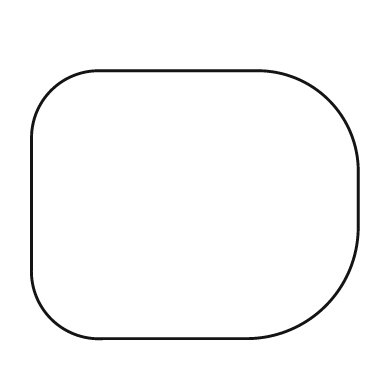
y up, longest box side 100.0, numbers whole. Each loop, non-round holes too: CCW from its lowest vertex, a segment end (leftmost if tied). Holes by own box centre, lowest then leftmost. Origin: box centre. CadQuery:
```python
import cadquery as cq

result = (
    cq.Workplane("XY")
    .moveTo(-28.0, -41.0)
    .lineTo(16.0, -41.0)
    .threePointArc((40.0, -31.0), (50.0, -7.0))
    .lineTo(50.0, 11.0)
    .threePointArc((41.0, 32.0), (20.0, 41.0))
    .lineTo(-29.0, 41.0)
    .threePointArc((-44.0, 35.0), (-50.0, 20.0))
    .lineTo(-50.0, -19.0)
    .threePointArc((-44.0, -35.0), (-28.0, -41.0))
    .close()
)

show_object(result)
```